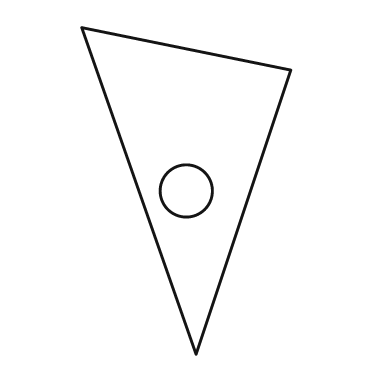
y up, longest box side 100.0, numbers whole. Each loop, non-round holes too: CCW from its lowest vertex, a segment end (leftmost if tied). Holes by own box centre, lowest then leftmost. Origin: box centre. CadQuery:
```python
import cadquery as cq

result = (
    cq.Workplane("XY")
    .moveTo(3.0, -50.0)
    .lineTo(32.0, 37.0)
    .lineTo(-32.0, 50.0)
    .close()
    .moveTo(0.0, 0.0)
    .circle(8.0)
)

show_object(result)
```